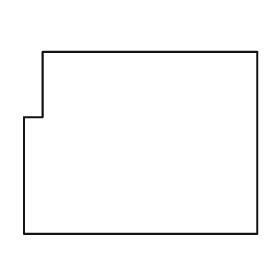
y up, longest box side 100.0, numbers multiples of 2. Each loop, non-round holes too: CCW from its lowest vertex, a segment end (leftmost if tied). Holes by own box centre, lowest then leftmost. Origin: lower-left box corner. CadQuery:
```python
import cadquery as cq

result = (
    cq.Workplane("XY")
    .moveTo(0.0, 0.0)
    .lineTo(100.0, 0.0)
    .lineTo(100.0, 78.0)
    .lineTo(8.0, 78.0)
    .lineTo(8.0, 50.0)
    .lineTo(0.0, 50.0)
    .close()
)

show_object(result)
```